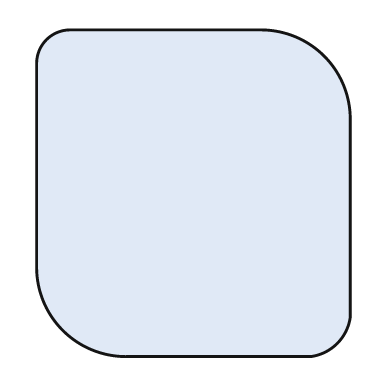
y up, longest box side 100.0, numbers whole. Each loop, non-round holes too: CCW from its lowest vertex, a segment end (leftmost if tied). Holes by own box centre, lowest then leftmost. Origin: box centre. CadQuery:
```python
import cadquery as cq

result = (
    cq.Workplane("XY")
    .moveTo(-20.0, -50.0)
    .lineTo(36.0, -50.0)
    .threePointArc((44.0, -46.0), (48.0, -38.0))
    .lineTo(48.0, 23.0)
    .threePointArc((40.0, 42.0), (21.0, 50.0))
    .lineTo(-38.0, 50.0)
    .threePointArc((-45.0, 47.0), (-48.0, 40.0))
    .lineTo(-48.0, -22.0)
    .threePointArc((-40.0, -42.0), (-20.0, -50.0))
    .close()
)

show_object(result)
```